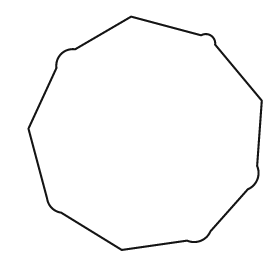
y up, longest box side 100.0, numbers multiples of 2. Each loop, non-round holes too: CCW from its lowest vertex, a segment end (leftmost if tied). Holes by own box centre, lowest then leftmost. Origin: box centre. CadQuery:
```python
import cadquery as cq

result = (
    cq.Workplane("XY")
    .moveTo(-10.0, -50.0)
    .lineTo(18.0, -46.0)
    .threePointArc((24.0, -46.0), (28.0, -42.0))
    .lineTo(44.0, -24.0)
    .threePointArc((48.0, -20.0), (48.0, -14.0))
    .lineTo(50.0, 14.0)
    .lineTo(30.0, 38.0)
    .threePointArc((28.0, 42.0), (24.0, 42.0))
    .lineTo(-6.0, 50.0)
    .lineTo(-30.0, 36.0)
    .threePointArc((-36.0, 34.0), (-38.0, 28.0))
    .lineTo(-50.0, 2.0)
    .lineTo(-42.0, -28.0)
    .threePointArc((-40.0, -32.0), (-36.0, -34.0))
    .close()
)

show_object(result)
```